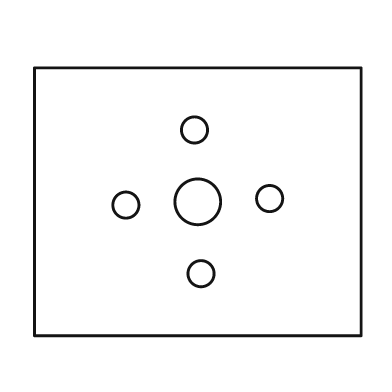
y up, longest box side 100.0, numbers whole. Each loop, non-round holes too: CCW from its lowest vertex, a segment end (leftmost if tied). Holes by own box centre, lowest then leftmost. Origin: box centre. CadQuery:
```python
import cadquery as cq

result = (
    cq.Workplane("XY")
    .moveTo(-50.0, -41.0)
    .lineTo(50.0, -41.0)
    .lineTo(50.0, 41.0)
    .lineTo(-50.0, 41.0)
    .close()
    .moveTo(1.0, -22.0)
    .circle(4.0)
    .moveTo(-22.0, -1.0)
    .circle(4.0)
    .moveTo(0.0, 0.0)
    .circle(7.0)
    .moveTo(22.0, 1.0)
    .circle(4.0)
    .moveTo(-1.0, 22.0)
    .circle(4.0)
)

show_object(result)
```